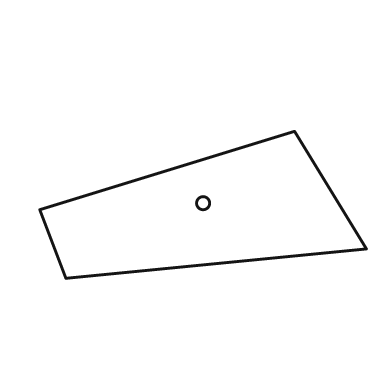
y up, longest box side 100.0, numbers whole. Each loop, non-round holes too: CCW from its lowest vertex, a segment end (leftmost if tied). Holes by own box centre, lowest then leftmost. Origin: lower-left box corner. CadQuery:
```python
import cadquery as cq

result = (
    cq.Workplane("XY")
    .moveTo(8.0, 0.0)
    .lineTo(100.0, 9.0)
    .lineTo(78.0, 45.0)
    .lineTo(0.0, 21.0)
    .close()
    .moveTo(50.0, 23.0)
    .circle(2.0)
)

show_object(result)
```